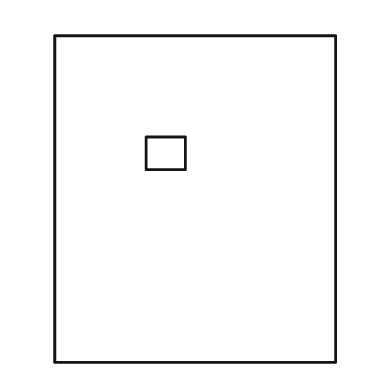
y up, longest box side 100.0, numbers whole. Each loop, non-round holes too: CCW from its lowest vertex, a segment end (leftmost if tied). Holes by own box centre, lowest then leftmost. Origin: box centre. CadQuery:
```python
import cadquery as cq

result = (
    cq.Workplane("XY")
    .moveTo(-43.0, -50.0)
    .lineTo(43.0, -50.0)
    .lineTo(43.0, 50.0)
    .lineTo(-43.0, 50.0)
    .close()
    .moveTo(-15.0, 9.0)
    .lineTo(-3.0, 9.0)
    .lineTo(-3.0, 19.0)
    .lineTo(-15.0, 19.0)
    .close()
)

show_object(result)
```